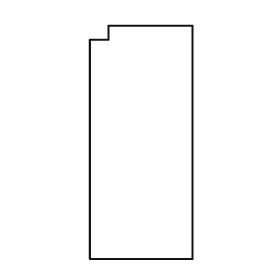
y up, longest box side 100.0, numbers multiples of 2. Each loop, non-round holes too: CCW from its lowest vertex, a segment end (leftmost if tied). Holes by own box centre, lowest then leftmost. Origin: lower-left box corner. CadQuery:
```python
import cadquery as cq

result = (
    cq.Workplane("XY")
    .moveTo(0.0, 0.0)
    .lineTo(44.0, 0.0)
    .lineTo(44.0, 100.0)
    .lineTo(8.0, 100.0)
    .lineTo(8.0, 94.0)
    .lineTo(0.0, 94.0)
    .close()
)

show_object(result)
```